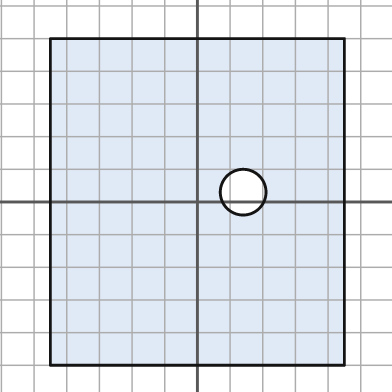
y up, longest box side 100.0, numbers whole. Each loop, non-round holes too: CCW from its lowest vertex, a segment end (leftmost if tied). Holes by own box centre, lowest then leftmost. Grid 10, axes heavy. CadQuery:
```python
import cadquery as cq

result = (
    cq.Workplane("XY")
    .moveTo(-45.0, -50.0)
    .lineTo(45.0, -50.0)
    .lineTo(45.0, 50.0)
    .lineTo(-45.0, 50.0)
    .close()
    .moveTo(14.0, 3.0)
    .circle(7.0)
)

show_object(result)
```